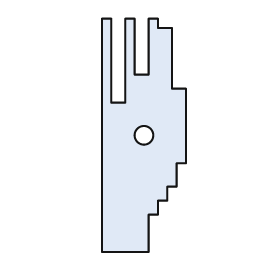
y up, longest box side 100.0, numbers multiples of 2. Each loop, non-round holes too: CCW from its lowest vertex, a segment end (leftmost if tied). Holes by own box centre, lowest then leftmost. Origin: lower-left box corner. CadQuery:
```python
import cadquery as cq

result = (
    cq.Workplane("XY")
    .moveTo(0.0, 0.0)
    .lineTo(20.0, 0.0)
    .lineTo(20.0, 16.0)
    .lineTo(24.0, 16.0)
    .lineTo(24.0, 22.0)
    .lineTo(28.0, 22.0)
    .lineTo(28.0, 28.0)
    .lineTo(32.0, 28.0)
    .lineTo(32.0, 38.0)
    .lineTo(36.0, 38.0)
    .lineTo(36.0, 70.0)
    .lineTo(30.0, 70.0)
    .lineTo(30.0, 96.0)
    .lineTo(24.0, 96.0)
    .lineTo(24.0, 100.0)
    .lineTo(20.0, 100.0)
    .lineTo(20.0, 76.0)
    .lineTo(14.0, 76.0)
    .lineTo(14.0, 100.0)
    .lineTo(10.0, 100.0)
    .lineTo(10.0, 64.0)
    .lineTo(4.0, 64.0)
    .lineTo(4.0, 100.0)
    .lineTo(0.0, 100.0)
    .close()
    .moveTo(18.0, 50.0)
    .circle(4.0)
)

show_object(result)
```